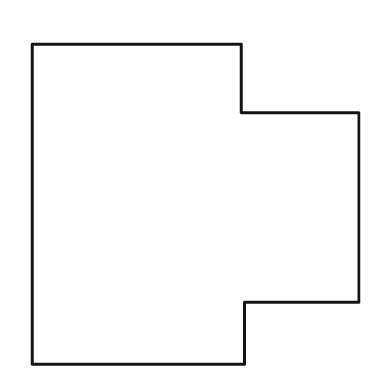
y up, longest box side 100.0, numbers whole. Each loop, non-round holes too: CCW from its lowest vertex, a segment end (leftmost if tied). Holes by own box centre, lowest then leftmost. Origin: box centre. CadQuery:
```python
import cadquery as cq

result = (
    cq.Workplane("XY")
    .moveTo(-50.0, -49.0)
    .lineTo(15.0, -49.0)
    .lineTo(15.0, -30.0)
    .lineTo(50.0, -30.0)
    .lineTo(50.0, 28.0)
    .lineTo(14.0, 28.0)
    .lineTo(14.0, 49.0)
    .lineTo(-50.0, 49.0)
    .close()
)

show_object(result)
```